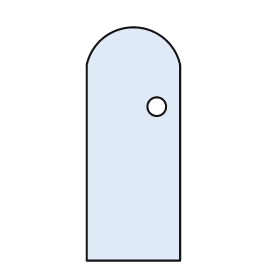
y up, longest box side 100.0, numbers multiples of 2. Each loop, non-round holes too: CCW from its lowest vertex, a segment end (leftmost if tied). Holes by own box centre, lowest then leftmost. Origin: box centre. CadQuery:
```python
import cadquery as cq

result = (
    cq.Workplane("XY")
    .moveTo(-20.0, -50.0)
    .lineTo(20.0, -50.0)
    .lineTo(20.0, 34.0)
    .threePointArc((0.0, 50.0), (-20.0, 34.0))
    .close()
    .moveTo(10.0, 16.0)
    .circle(4.0)
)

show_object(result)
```